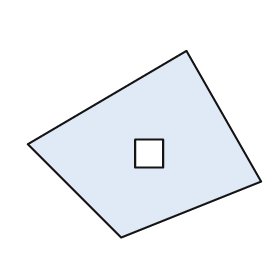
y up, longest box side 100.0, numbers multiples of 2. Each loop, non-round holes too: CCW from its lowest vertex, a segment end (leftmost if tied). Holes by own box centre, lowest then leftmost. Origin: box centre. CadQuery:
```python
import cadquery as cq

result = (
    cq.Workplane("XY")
    .moveTo(-10.0, -40.0)
    .lineTo(50.0, -16.0)
    .lineTo(18.0, 40.0)
    .lineTo(-50.0, 0.0)
    .close()
    .moveTo(-4.0, -10.0)
    .lineTo(8.0, -10.0)
    .lineTo(8.0, 2.0)
    .lineTo(-4.0, 2.0)
    .close()
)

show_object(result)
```